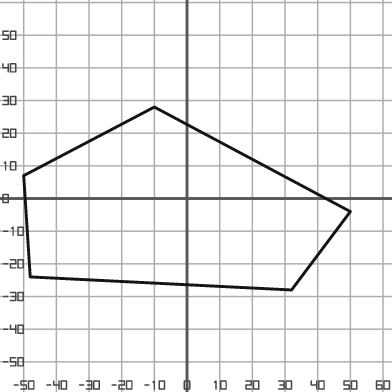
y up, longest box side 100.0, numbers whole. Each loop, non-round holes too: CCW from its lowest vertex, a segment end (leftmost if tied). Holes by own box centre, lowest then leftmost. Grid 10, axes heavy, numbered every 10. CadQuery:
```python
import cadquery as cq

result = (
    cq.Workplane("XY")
    .moveTo(32.0, -28.0)
    .lineTo(50.0, -4.0)
    .lineTo(-10.0, 28.0)
    .lineTo(-50.0, 7.0)
    .lineTo(-48.0, -24.0)
    .close()
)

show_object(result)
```